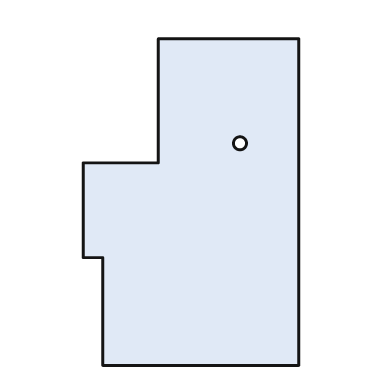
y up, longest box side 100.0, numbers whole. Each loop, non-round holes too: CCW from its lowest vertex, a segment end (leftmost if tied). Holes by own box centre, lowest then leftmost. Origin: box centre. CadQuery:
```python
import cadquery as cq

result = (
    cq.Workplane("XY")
    .moveTo(-27.0, -50.0)
    .lineTo(33.0, -50.0)
    .lineTo(33.0, 50.0)
    .lineTo(-10.0, 50.0)
    .lineTo(-10.0, 12.0)
    .lineTo(-33.0, 12.0)
    .lineTo(-33.0, -17.0)
    .lineTo(-27.0, -17.0)
    .close()
    .moveTo(15.0, 18.0)
    .circle(2.0)
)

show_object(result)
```